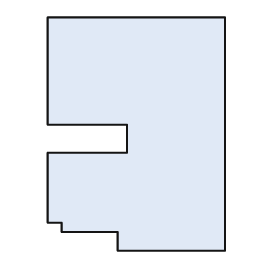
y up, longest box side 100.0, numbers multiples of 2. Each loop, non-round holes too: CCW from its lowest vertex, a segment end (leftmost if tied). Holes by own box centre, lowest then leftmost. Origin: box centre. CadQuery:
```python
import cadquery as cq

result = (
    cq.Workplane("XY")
    .moveTo(-8.0, -50.0)
    .lineTo(38.0, -50.0)
    .lineTo(38.0, 50.0)
    .lineTo(-38.0, 50.0)
    .lineTo(-38.0, 4.0)
    .lineTo(-4.0, 4.0)
    .lineTo(-4.0, -8.0)
    .lineTo(-38.0, -8.0)
    .lineTo(-38.0, -38.0)
    .lineTo(-32.0, -38.0)
    .lineTo(-32.0, -42.0)
    .lineTo(-8.0, -42.0)
    .close()
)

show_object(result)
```